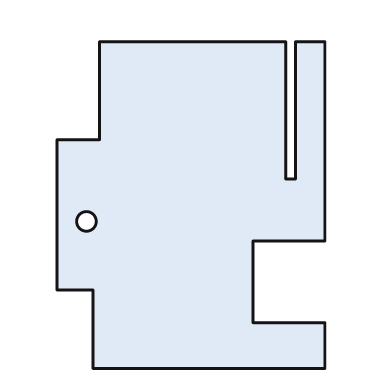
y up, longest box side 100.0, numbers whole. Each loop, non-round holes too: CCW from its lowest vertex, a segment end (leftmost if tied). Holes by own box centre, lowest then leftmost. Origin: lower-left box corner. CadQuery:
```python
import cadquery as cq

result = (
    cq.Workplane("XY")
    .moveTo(11.0, 0.0)
    .lineTo(82.0, 0.0)
    .lineTo(82.0, 14.0)
    .lineTo(60.0, 14.0)
    .lineTo(60.0, 39.0)
    .lineTo(82.0, 39.0)
    .lineTo(82.0, 100.0)
    .lineTo(73.0, 100.0)
    .lineTo(73.0, 58.0)
    .lineTo(70.0, 58.0)
    .lineTo(70.0, 100.0)
    .lineTo(13.0, 100.0)
    .lineTo(13.0, 70.0)
    .lineTo(0.0, 70.0)
    .lineTo(0.0, 24.0)
    .lineTo(11.0, 24.0)
    .close()
    .moveTo(9.0, 45.0)
    .circle(3.0)
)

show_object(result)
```